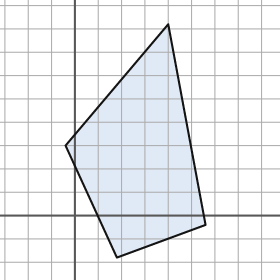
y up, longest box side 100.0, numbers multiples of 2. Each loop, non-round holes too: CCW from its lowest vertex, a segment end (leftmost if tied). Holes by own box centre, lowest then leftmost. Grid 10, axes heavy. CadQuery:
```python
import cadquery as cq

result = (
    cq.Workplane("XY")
    .moveTo(18.0, -18.0)
    .lineTo(56.0, -4.0)
    .lineTo(40.0, 82.0)
    .lineTo(-4.0, 30.0)
    .close()
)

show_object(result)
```